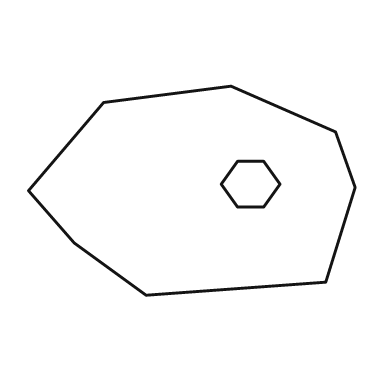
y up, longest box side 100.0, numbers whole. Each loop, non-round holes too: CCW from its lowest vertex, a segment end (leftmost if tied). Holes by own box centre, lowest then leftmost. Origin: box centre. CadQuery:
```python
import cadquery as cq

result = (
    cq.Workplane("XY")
    .moveTo(-14.0, -32.0)
    .lineTo(41.0, -28.0)
    .lineTo(50.0, 1.0)
    .lineTo(44.0, 18.0)
    .lineTo(12.0, 32.0)
    .lineTo(-27.0, 27.0)
    .lineTo(-50.0, 0.0)
    .lineTo(-36.0, -16.0)
    .close()
    .moveTo(14.0, -5.0)
    .lineTo(22.0, -5.0)
    .lineTo(27.0, 2.0)
    .lineTo(22.0, 9.0)
    .lineTo(14.0, 9.0)
    .lineTo(9.0, 2.0)
    .close()
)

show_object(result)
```